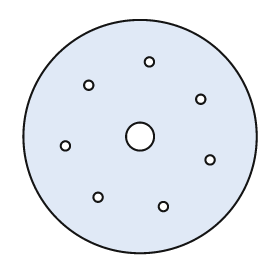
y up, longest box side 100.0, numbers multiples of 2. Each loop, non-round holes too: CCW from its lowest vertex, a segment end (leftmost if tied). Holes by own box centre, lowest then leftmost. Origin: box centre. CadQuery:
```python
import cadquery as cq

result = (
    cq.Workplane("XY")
    .moveTo(0.0, 0.0)
    .circle(50.0)
    .moveTo(10.0, -30.0)
    .circle(2.0)
    .moveTo(-18.0, -26.0)
    .circle(2.0)
    .moveTo(30.0, -10.0)
    .circle(2.0)
    .moveTo(-32.0, -4.0)
    .circle(2.0)
    .moveTo(0.0, 0.0)
    .circle(6.0)
    .moveTo(26.0, 16.0)
    .circle(2.0)
    .moveTo(-22.0, 22.0)
    .circle(2.0)
    .moveTo(4.0, 32.0)
    .circle(2.0)
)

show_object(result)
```